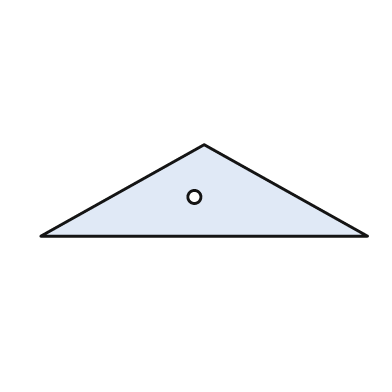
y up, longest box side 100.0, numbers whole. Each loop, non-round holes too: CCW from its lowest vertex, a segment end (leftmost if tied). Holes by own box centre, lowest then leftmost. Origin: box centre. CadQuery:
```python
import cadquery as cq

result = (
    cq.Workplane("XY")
    .moveTo(-50.0, -14.0)
    .lineTo(50.0, -14.0)
    .lineTo(0.0, 14.0)
    .close()
    .moveTo(-3.0, -2.0)
    .circle(2.0)
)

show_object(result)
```